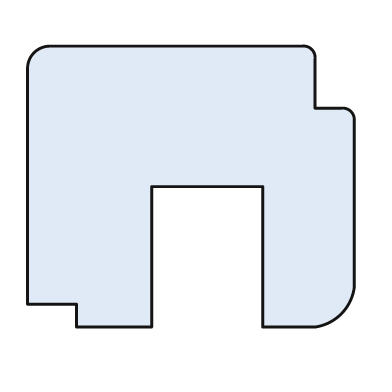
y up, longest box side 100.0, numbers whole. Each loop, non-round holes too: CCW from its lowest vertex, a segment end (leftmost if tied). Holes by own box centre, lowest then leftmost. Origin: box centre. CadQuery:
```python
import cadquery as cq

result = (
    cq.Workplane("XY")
    .moveTo(-35.0, -43.0)
    .lineTo(-12.0, -43.0)
    .lineTo(-12.0, 0.0)
    .lineTo(22.0, 0.0)
    .lineTo(22.0, -43.0)
    .lineTo(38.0, -43.0)
    .threePointArc((46.0, -39.0), (50.0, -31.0))
    .lineTo(50.0, 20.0)
    .threePointArc((49.0, 23.0), (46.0, 24.0))
    .lineTo(38.0, 24.0)
    .lineTo(38.0, 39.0)
    .threePointArc((37.0, 42.0), (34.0, 43.0))
    .lineTo(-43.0, 43.0)
    .threePointArc((-48.0, 41.0), (-50.0, 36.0))
    .lineTo(-50.0, -36.0)
    .lineTo(-35.0, -36.0)
    .close()
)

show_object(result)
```